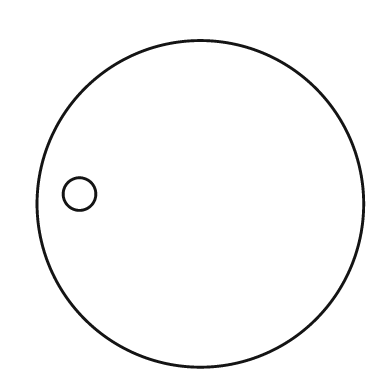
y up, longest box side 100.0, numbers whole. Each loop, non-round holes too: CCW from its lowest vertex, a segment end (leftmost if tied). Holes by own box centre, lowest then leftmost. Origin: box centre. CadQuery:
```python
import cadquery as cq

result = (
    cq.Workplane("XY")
    .moveTo(0.0, 0.0)
    .circle(50.0)
    .moveTo(-37.0, 3.0)
    .circle(5.0)
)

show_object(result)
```